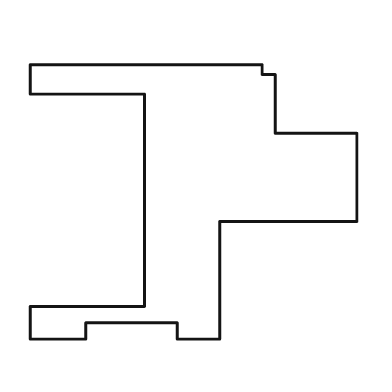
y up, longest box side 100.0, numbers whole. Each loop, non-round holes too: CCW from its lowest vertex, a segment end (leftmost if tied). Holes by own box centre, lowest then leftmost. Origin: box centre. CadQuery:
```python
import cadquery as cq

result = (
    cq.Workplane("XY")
    .moveTo(-50.0, -42.0)
    .lineTo(-33.0, -42.0)
    .lineTo(-33.0, -37.0)
    .lineTo(-5.0, -37.0)
    .lineTo(-5.0, -42.0)
    .lineTo(8.0, -42.0)
    .lineTo(8.0, -6.0)
    .lineTo(50.0, -6.0)
    .lineTo(50.0, 21.0)
    .lineTo(25.0, 21.0)
    .lineTo(25.0, 39.0)
    .lineTo(21.0, 39.0)
    .lineTo(21.0, 42.0)
    .lineTo(-50.0, 42.0)
    .lineTo(-50.0, 33.0)
    .lineTo(-15.0, 33.0)
    .lineTo(-15.0, -32.0)
    .lineTo(-50.0, -32.0)
    .close()
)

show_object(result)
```